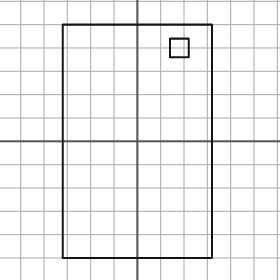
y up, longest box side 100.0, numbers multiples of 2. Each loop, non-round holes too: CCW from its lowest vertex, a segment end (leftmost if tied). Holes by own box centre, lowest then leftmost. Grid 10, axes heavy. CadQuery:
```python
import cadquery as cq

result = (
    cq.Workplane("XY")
    .moveTo(-32.0, -50.0)
    .lineTo(32.0, -50.0)
    .lineTo(32.0, 50.0)
    .lineTo(-32.0, 50.0)
    .close()
    .moveTo(14.0, 36.0)
    .lineTo(22.0, 36.0)
    .lineTo(22.0, 44.0)
    .lineTo(14.0, 44.0)
    .close()
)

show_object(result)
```